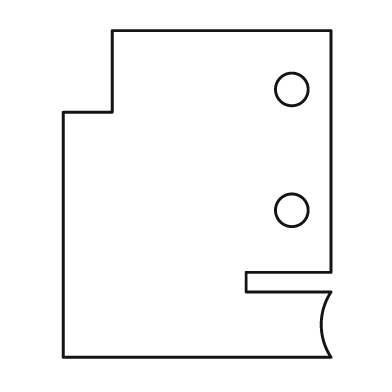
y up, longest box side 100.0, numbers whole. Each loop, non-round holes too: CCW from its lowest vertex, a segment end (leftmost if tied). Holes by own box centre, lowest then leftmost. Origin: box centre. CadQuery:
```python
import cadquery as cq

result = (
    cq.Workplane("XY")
    .moveTo(-41.0, -50.0)
    .lineTo(41.0, -50.0)
    .threePointArc((38.0, -40.0), (41.0, -30.0))
    .lineTo(15.0, -30.0)
    .lineTo(15.0, -24.0)
    .lineTo(41.0, -24.0)
    .lineTo(41.0, 50.0)
    .lineTo(-26.0, 50.0)
    .lineTo(-26.0, 25.0)
    .lineTo(-41.0, 25.0)
    .close()
    .moveTo(29.0, -5.0)
    .circle(5.0)
    .moveTo(29.0, 32.0)
    .circle(5.0)
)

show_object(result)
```